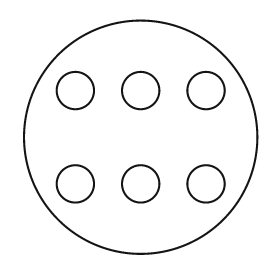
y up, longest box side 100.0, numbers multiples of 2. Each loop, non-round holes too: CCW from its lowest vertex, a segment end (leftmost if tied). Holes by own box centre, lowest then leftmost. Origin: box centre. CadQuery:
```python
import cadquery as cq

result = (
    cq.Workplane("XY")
    .moveTo(0.0, 0.0)
    .circle(50.0)
    .moveTo(-28.0, -20.0)
    .circle(8.0)
    .moveTo(0.0, -20.0)
    .circle(8.0)
    .moveTo(28.0, -20.0)
    .circle(8.0)
    .moveTo(-28.0, 20.0)
    .circle(8.0)
    .moveTo(0.0, 20.0)
    .circle(8.0)
    .moveTo(28.0, 20.0)
    .circle(8.0)
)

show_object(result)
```